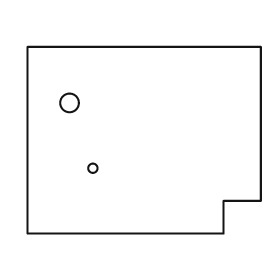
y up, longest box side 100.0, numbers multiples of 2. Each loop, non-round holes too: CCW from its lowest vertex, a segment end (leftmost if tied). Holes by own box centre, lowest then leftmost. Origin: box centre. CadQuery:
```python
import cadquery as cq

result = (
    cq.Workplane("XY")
    .moveTo(-50.0, -40.0)
    .lineTo(34.0, -40.0)
    .lineTo(34.0, -26.0)
    .lineTo(50.0, -26.0)
    .lineTo(50.0, 40.0)
    .lineTo(-50.0, 40.0)
    .close()
    .moveTo(-22.0, -12.0)
    .circle(2.0)
    .moveTo(-32.0, 16.0)
    .circle(4.0)
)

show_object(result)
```